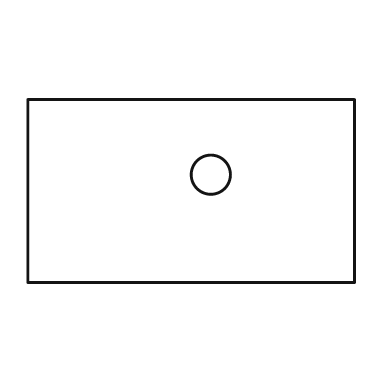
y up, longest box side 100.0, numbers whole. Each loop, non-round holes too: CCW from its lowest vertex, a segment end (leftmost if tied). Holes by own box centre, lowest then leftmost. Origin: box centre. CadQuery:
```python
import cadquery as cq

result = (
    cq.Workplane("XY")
    .moveTo(-50.0, -28.0)
    .lineTo(50.0, -28.0)
    .lineTo(50.0, 28.0)
    .lineTo(-50.0, 28.0)
    .close()
    .moveTo(6.0, 5.0)
    .circle(6.0)
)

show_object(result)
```